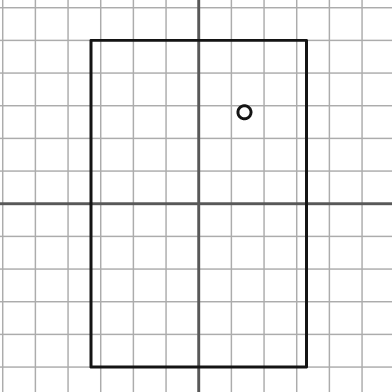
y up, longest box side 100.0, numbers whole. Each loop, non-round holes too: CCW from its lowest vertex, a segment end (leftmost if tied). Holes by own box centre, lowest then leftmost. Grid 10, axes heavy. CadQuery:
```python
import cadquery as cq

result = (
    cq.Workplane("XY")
    .moveTo(-33.0, -50.0)
    .lineTo(33.0, -50.0)
    .lineTo(33.0, 50.0)
    .lineTo(-33.0, 50.0)
    .close()
    .moveTo(14.0, 28.0)
    .circle(2.0)
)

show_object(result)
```